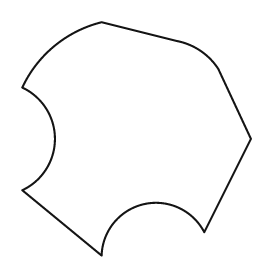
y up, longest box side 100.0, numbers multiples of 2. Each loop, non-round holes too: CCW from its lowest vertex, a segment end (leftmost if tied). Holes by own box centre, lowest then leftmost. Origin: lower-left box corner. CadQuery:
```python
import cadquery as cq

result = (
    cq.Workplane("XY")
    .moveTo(34.0, 0.0)
    .threePointArc((52.0, 22.0), (78.0, 10.0))
    .lineTo(98.0, 50.0)
    .lineTo(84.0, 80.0)
    .threePointArc((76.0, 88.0), (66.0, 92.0))
    .lineTo(34.0, 100.0)
    .threePointArc((14.0, 90.0), (0.0, 72.0))
    .threePointArc((14.0, 50.0), (0.0, 28.0))
    .close()
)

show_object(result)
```